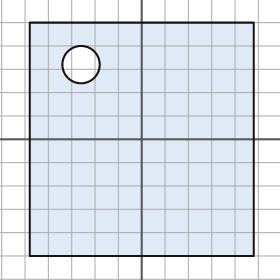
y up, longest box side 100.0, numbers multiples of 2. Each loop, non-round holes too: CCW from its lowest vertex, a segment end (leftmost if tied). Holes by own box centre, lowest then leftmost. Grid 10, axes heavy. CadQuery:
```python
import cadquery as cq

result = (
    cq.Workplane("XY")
    .moveTo(-48.0, -50.0)
    .lineTo(48.0, -50.0)
    .lineTo(48.0, 50.0)
    .lineTo(-48.0, 50.0)
    .close()
    .moveTo(-26.0, 32.0)
    .circle(8.0)
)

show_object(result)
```